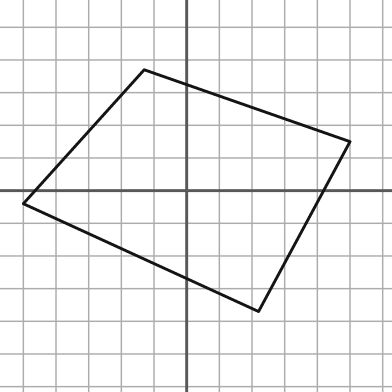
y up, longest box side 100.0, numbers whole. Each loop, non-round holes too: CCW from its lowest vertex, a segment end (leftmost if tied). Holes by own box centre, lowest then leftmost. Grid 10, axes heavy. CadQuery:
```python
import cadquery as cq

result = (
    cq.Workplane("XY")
    .moveTo(22.0, -37.0)
    .lineTo(50.0, 15.0)
    .lineTo(-13.0, 37.0)
    .lineTo(-50.0, -4.0)
    .close()
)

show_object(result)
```